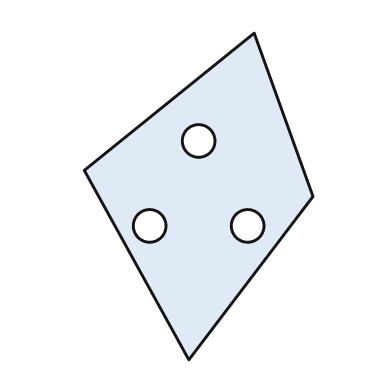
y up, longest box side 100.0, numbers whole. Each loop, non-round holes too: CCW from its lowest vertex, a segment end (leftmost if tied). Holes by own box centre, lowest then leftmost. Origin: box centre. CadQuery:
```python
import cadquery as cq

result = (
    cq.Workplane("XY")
    .moveTo(-3.0, -50.0)
    .lineTo(35.0, 0.0)
    .lineTo(17.0, 50.0)
    .lineTo(-35.0, 8.0)
    .close()
    .moveTo(-15.0, -9.0)
    .circle(5.0)
    .moveTo(15.0, -9.0)
    .circle(5.0)
    .moveTo(0.0, 17.0)
    .circle(5.0)
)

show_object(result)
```